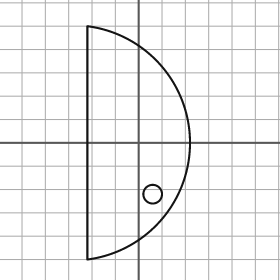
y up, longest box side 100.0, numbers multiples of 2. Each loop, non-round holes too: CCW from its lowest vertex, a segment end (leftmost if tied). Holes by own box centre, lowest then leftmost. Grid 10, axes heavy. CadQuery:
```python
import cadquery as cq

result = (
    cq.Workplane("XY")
    .moveTo(-22.0, -50.0)
    .threePointArc((22.0, 0.0), (-22.0, 50.0))
    .close()
    .moveTo(6.0, -22.0)
    .circle(4.0)
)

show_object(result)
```